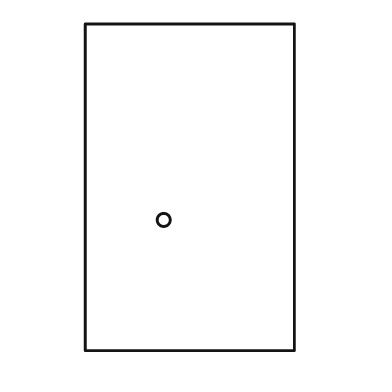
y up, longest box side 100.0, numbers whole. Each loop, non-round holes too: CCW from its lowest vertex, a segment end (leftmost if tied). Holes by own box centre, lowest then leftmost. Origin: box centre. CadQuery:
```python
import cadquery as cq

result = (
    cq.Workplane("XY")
    .moveTo(-32.0, -50.0)
    .lineTo(32.0, -50.0)
    .lineTo(32.0, 50.0)
    .lineTo(-32.0, 50.0)
    .close()
    .moveTo(-8.0, -10.0)
    .circle(2.0)
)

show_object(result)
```